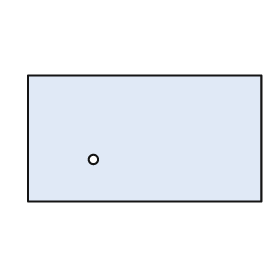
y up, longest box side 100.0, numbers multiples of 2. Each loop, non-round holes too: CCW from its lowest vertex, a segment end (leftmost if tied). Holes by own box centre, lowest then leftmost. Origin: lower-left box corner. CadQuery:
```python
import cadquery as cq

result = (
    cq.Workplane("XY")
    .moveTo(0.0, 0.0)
    .lineTo(100.0, 0.0)
    .lineTo(100.0, 54.0)
    .lineTo(0.0, 54.0)
    .close()
    .moveTo(28.0, 18.0)
    .circle(2.0)
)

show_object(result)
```